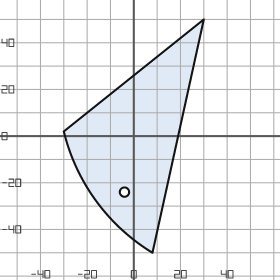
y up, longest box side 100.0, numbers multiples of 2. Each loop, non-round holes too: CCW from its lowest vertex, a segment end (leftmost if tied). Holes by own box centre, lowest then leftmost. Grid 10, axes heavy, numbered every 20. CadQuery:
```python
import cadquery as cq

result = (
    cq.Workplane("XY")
    .moveTo(8.0, -50.0)
    .lineTo(30.0, 50.0)
    .lineTo(-30.0, 2.0)
    .threePointArc((-16.0, -28.0), (8.0, -50.0))
    .close()
    .moveTo(-4.0, -24.0)
    .circle(2.0)
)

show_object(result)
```